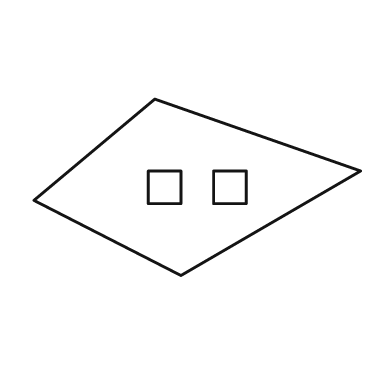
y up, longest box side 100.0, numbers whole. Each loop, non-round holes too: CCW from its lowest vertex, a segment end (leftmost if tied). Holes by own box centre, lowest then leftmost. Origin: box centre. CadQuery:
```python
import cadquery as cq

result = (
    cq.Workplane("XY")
    .moveTo(-5.0, -27.0)
    .lineTo(50.0, 5.0)
    .lineTo(-13.0, 27.0)
    .lineTo(-50.0, -4.0)
    .close()
    .moveTo(-15.0, -5.0)
    .lineTo(-5.0, -5.0)
    .lineTo(-5.0, 5.0)
    .lineTo(-15.0, 5.0)
    .close()
    .moveTo(5.0, -5.0)
    .lineTo(15.0, -5.0)
    .lineTo(15.0, 5.0)
    .lineTo(5.0, 5.0)
    .close()
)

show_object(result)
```